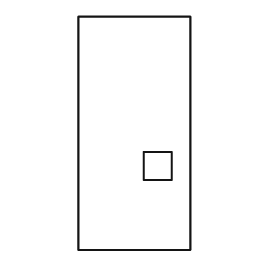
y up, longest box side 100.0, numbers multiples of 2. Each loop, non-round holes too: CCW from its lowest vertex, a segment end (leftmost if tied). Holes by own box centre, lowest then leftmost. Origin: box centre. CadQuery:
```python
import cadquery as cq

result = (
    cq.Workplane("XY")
    .moveTo(-24.0, -50.0)
    .lineTo(24.0, -50.0)
    .lineTo(24.0, 50.0)
    .lineTo(-24.0, 50.0)
    .close()
    .moveTo(4.0, -20.0)
    .lineTo(16.0, -20.0)
    .lineTo(16.0, -8.0)
    .lineTo(4.0, -8.0)
    .close()
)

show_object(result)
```